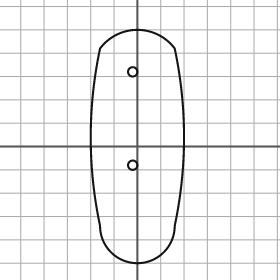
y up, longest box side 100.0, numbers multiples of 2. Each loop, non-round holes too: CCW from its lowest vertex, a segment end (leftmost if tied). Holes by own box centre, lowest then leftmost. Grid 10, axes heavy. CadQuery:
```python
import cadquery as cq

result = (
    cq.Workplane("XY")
    .moveTo(-16.0, -34.0)
    .threePointArc((0.0, -50.0), (16.0, -34.0))
    .threePointArc((20.0, 4.0), (16.0, 42.0))
    .threePointArc((0.0, 50.0), (-16.0, 42.0))
    .threePointArc((-20.0, 4.0), (-16.0, -34.0))
    .close()
    .moveTo(-2.0, -8.0)
    .circle(2.0)
    .moveTo(-2.0, 32.0)
    .circle(2.0)
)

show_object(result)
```